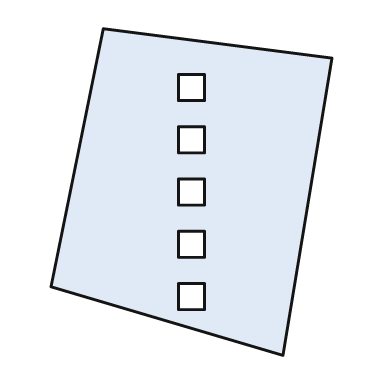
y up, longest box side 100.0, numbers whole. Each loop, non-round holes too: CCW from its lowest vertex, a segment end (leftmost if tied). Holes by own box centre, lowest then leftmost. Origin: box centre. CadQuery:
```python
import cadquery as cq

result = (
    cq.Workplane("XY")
    .moveTo(28.0, -50.0)
    .lineTo(43.0, 41.0)
    .lineTo(-27.0, 50.0)
    .lineTo(-43.0, -29.0)
    .close()
    .moveTo(-4.0, -36.0)
    .lineTo(4.0, -36.0)
    .lineTo(4.0, -28.0)
    .lineTo(-4.0, -28.0)
    .close()
    .moveTo(-4.0, -20.0)
    .lineTo(4.0, -20.0)
    .lineTo(4.0, -12.0)
    .lineTo(-4.0, -12.0)
    .close()
    .moveTo(-4.0, -4.0)
    .lineTo(4.0, -4.0)
    .lineTo(4.0, 4.0)
    .lineTo(-4.0, 4.0)
    .close()
    .moveTo(-4.0, 12.0)
    .lineTo(4.0, 12.0)
    .lineTo(4.0, 20.0)
    .lineTo(-4.0, 20.0)
    .close()
    .moveTo(-4.0, 28.0)
    .lineTo(4.0, 28.0)
    .lineTo(4.0, 36.0)
    .lineTo(-4.0, 36.0)
    .close()
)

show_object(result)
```